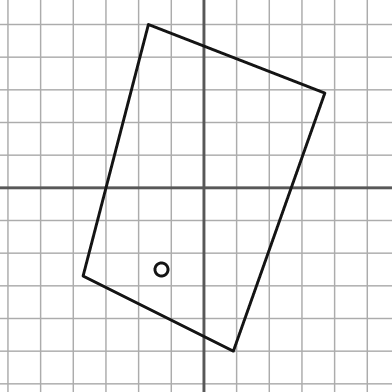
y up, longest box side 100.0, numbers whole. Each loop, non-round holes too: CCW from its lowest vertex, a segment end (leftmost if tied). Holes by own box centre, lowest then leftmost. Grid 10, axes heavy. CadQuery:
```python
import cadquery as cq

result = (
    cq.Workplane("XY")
    .moveTo(9.0, -50.0)
    .lineTo(37.0, 29.0)
    .lineTo(-17.0, 50.0)
    .lineTo(-37.0, -27.0)
    .close()
    .moveTo(-13.0, -25.0)
    .circle(2.0)
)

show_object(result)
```